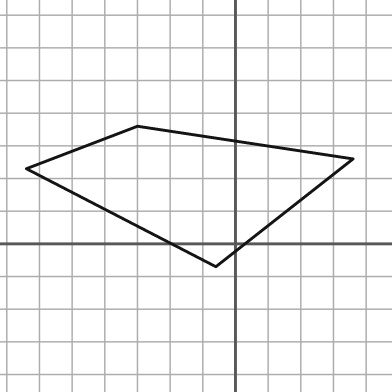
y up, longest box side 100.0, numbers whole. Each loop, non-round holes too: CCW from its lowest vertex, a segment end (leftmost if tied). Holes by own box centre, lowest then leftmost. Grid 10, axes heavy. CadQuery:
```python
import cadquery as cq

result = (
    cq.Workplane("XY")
    .moveTo(-6.0, -7.0)
    .lineTo(36.0, 26.0)
    .lineTo(-30.0, 36.0)
    .lineTo(-64.0, 23.0)
    .close()
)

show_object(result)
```